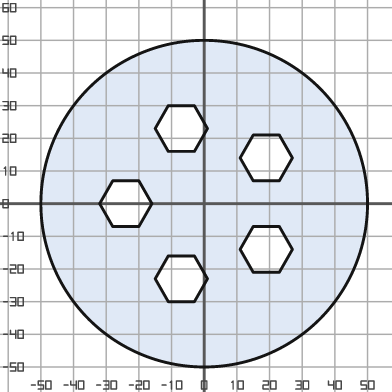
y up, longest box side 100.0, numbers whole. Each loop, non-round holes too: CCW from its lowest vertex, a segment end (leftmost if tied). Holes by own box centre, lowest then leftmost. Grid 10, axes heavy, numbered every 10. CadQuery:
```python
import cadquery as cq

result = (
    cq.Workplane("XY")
    .moveTo(0.0, 0.0)
    .circle(50.0)
    .moveTo(-11.0, -30.0)
    .lineTo(-3.0, -30.0)
    .lineTo(1.0, -23.0)
    .lineTo(-3.0, -16.0)
    .lineTo(-11.0, -16.0)
    .lineTo(-15.0, -23.0)
    .close()
    .moveTo(15.0, -21.0)
    .lineTo(23.0, -21.0)
    .lineTo(27.0, -14.0)
    .lineTo(23.0, -7.0)
    .lineTo(15.0, -7.0)
    .lineTo(11.0, -14.0)
    .close()
    .moveTo(-28.0, -7.0)
    .lineTo(-20.0, -7.0)
    .lineTo(-16.0, 0.0)
    .lineTo(-20.0, 7.0)
    .lineTo(-28.0, 7.0)
    .lineTo(-32.0, 0.0)
    .close()
    .moveTo(15.0, 7.0)
    .lineTo(23.0, 7.0)
    .lineTo(27.0, 14.0)
    .lineTo(23.0, 21.0)
    .lineTo(15.0, 21.0)
    .lineTo(11.0, 14.0)
    .close()
    .moveTo(-11.0, 16.0)
    .lineTo(-3.0, 16.0)
    .lineTo(1.0, 23.0)
    .lineTo(-3.0, 30.0)
    .lineTo(-11.0, 30.0)
    .lineTo(-15.0, 23.0)
    .close()
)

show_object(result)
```